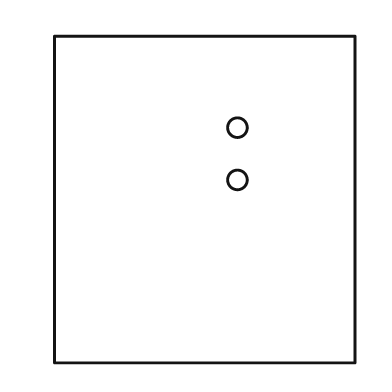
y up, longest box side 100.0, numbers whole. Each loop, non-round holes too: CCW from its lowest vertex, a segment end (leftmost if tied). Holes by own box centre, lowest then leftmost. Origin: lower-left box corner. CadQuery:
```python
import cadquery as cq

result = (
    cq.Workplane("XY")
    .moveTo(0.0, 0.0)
    .lineTo(92.0, 0.0)
    .lineTo(92.0, 100.0)
    .lineTo(0.0, 100.0)
    .close()
    .moveTo(56.0, 56.0)
    .circle(3.0)
    .moveTo(56.0, 72.0)
    .circle(3.0)
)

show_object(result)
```